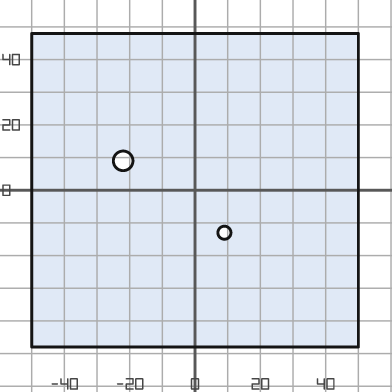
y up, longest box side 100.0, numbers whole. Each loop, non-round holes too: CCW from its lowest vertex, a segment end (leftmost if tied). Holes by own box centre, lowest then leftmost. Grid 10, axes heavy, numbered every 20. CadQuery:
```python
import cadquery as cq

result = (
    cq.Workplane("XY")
    .moveTo(-50.0, -48.0)
    .lineTo(50.0, -48.0)
    .lineTo(50.0, 48.0)
    .lineTo(-50.0, 48.0)
    .close()
    .moveTo(9.0, -13.0)
    .circle(2.0)
    .moveTo(-22.0, 9.0)
    .circle(3.0)
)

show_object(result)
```